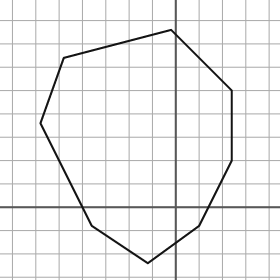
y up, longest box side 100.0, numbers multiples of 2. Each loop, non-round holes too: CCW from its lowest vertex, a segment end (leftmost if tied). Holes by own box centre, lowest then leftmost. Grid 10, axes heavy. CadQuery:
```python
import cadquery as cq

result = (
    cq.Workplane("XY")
    .moveTo(-12.0, -24.0)
    .lineTo(10.0, -8.0)
    .lineTo(24.0, 20.0)
    .lineTo(24.0, 50.0)
    .lineTo(-2.0, 76.0)
    .lineTo(-48.0, 64.0)
    .lineTo(-58.0, 36.0)
    .lineTo(-36.0, -8.0)
    .close()
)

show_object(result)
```